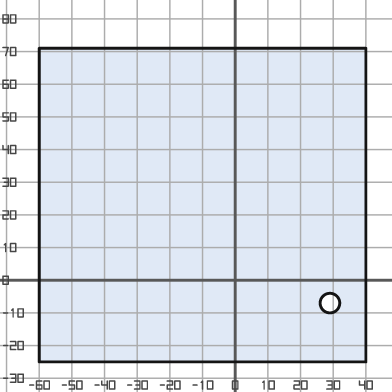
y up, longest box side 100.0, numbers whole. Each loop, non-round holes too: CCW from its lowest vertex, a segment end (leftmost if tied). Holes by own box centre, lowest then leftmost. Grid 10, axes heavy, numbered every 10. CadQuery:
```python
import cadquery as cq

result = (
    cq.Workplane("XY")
    .moveTo(-60.0, -25.0)
    .lineTo(40.0, -25.0)
    .lineTo(40.0, 71.0)
    .lineTo(-60.0, 71.0)
    .close()
    .moveTo(29.0, -7.0)
    .circle(3.0)
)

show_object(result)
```